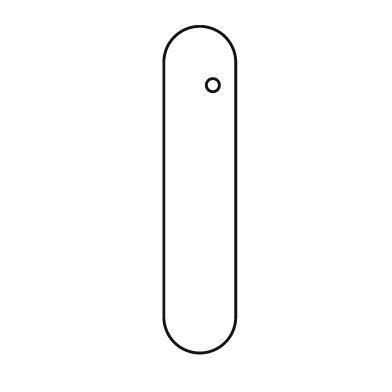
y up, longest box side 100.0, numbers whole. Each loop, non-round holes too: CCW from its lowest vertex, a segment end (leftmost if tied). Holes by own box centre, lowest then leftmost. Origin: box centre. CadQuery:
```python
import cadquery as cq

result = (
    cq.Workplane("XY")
    .moveTo(-11.0, -39.0)
    .threePointArc((0.0, -50.0), (11.0, -39.0))
    .lineTo(11.0, 39.0)
    .threePointArc((0.0, 50.0), (-11.0, 39.0))
    .close()
    .moveTo(4.0, 32.0)
    .circle(2.0)
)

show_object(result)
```